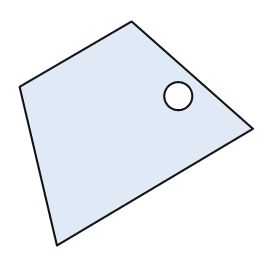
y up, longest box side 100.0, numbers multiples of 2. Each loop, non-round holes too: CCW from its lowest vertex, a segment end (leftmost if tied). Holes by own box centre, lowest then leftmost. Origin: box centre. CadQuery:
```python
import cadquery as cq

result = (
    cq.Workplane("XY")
    .moveTo(-34.0, -48.0)
    .lineTo(50.0, 2.0)
    .lineTo(-2.0, 48.0)
    .lineTo(-50.0, 20.0)
    .close()
    .moveTo(18.0, 16.0)
    .circle(6.0)
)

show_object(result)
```